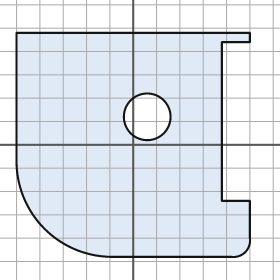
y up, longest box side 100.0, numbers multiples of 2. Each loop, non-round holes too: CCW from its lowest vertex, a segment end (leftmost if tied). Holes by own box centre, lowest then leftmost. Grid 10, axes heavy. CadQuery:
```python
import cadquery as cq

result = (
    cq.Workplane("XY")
    .moveTo(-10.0, -48.0)
    .lineTo(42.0, -48.0)
    .threePointArc((48.0, -46.0), (50.0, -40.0))
    .lineTo(50.0, -24.0)
    .lineTo(38.0, -24.0)
    .lineTo(38.0, 44.0)
    .lineTo(50.0, 44.0)
    .lineTo(50.0, 48.0)
    .lineTo(-50.0, 48.0)
    .lineTo(-50.0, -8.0)
    .threePointArc((-38.0, -36.0), (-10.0, -48.0))
    .close()
    .moveTo(6.0, 12.0)
    .circle(10.0)
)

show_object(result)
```